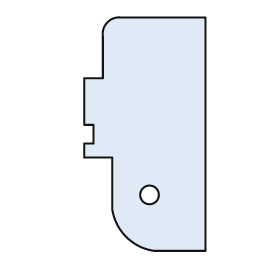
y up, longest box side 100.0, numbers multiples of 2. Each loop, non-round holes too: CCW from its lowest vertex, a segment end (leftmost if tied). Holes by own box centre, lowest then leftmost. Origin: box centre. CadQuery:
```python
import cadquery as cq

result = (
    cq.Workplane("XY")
    .moveTo(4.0, -50.0)
    .lineTo(26.0, -50.0)
    .lineTo(26.0, 50.0)
    .lineTo(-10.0, 50.0)
    .threePointArc((-16.0, 48.0), (-18.0, 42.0))
    .lineTo(-18.0, 24.0)
    .lineTo(-26.0, 24.0)
    .lineTo(-26.0, 4.0)
    .lineTo(-22.0, 4.0)
    .lineTo(-22.0, -4.0)
    .lineTo(-26.0, -4.0)
    .lineTo(-26.0, -10.0)
    .lineTo(-14.0, -10.0)
    .lineTo(-14.0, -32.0)
    .threePointArc((-8.0, -44.0), (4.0, -50.0))
    .close()
    .moveTo(2.0, -26.0)
    .circle(4.0)
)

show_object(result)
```